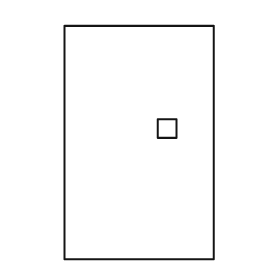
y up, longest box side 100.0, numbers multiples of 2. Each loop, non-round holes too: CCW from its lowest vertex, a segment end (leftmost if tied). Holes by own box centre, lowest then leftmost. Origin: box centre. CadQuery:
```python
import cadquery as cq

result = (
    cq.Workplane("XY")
    .moveTo(-32.0, -50.0)
    .lineTo(32.0, -50.0)
    .lineTo(32.0, 50.0)
    .lineTo(-32.0, 50.0)
    .close()
    .moveTo(8.0, 2.0)
    .lineTo(16.0, 2.0)
    .lineTo(16.0, 10.0)
    .lineTo(8.0, 10.0)
    .close()
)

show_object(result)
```